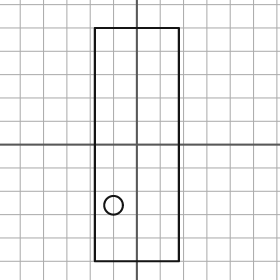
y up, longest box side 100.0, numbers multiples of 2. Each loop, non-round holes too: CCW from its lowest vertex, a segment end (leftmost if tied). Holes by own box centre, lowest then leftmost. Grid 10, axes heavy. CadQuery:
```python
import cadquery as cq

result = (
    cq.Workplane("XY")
    .moveTo(-18.0, -50.0)
    .lineTo(18.0, -50.0)
    .lineTo(18.0, 50.0)
    .lineTo(-18.0, 50.0)
    .close()
    .moveTo(-10.0, -26.0)
    .circle(4.0)
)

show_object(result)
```